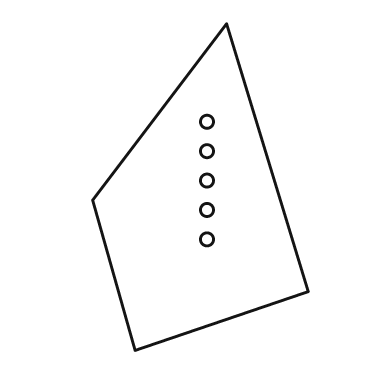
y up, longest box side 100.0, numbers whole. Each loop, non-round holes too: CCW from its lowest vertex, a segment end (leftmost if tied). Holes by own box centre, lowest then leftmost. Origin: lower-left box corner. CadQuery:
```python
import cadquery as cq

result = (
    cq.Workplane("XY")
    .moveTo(13.0, 0.0)
    .lineTo(66.0, 18.0)
    .lineTo(41.0, 100.0)
    .lineTo(0.0, 46.0)
    .close()
    .moveTo(35.0, 34.0)
    .circle(2.0)
    .moveTo(35.0, 43.0)
    .circle(2.0)
    .moveTo(35.0, 52.0)
    .circle(2.0)
    .moveTo(35.0, 61.0)
    .circle(2.0)
    .moveTo(35.0, 70.0)
    .circle(2.0)
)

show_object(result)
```